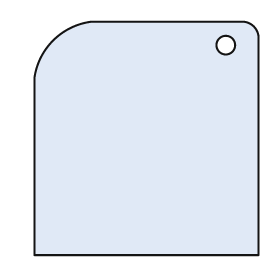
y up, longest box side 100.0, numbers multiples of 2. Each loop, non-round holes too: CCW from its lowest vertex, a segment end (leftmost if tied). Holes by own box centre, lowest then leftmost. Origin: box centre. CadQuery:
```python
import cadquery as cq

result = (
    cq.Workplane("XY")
    .moveTo(-48.0, -50.0)
    .lineTo(48.0, -50.0)
    .lineTo(48.0, 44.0)
    .threePointArc((46.0, 48.0), (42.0, 50.0))
    .lineTo(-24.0, 50.0)
    .threePointArc((-40.0, 42.0), (-48.0, 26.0))
    .close()
    .moveTo(34.0, 40.0)
    .circle(4.0)
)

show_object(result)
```